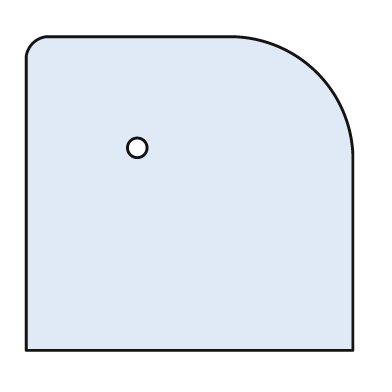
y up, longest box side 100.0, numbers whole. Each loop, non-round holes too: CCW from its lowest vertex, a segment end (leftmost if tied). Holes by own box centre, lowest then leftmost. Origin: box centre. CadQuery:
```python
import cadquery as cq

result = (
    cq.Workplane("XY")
    .moveTo(-50.0, -48.0)
    .lineTo(50.0, -48.0)
    .lineTo(50.0, 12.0)
    .threePointArc((39.0, 37.0), (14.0, 48.0))
    .lineTo(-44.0, 48.0)
    .threePointArc((-48.0, 46.0), (-50.0, 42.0))
    .close()
    .moveTo(-16.0, 14.0)
    .circle(3.0)
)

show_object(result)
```